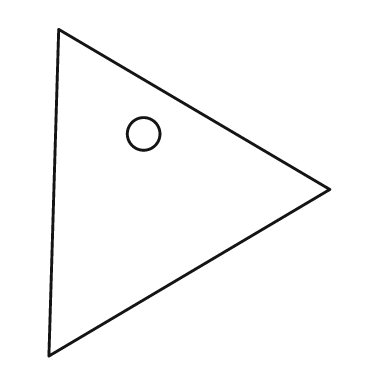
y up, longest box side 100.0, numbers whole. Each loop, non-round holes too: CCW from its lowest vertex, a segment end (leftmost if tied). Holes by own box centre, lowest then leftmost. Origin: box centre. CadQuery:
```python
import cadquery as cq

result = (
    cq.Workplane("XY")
    .moveTo(-43.0, -50.0)
    .lineTo(43.0, 1.0)
    .lineTo(-40.0, 50.0)
    .close()
    .moveTo(-14.0, 18.0)
    .circle(5.0)
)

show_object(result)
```